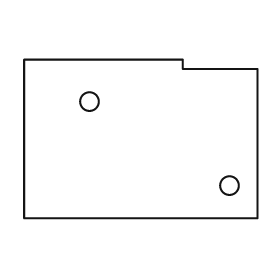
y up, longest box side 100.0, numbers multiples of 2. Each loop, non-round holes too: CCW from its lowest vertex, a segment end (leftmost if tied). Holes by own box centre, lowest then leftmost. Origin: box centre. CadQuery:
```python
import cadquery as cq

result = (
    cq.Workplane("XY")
    .moveTo(-50.0, -34.0)
    .lineTo(50.0, -34.0)
    .lineTo(50.0, 30.0)
    .lineTo(18.0, 30.0)
    .lineTo(18.0, 34.0)
    .lineTo(-50.0, 34.0)
    .close()
    .moveTo(38.0, -20.0)
    .circle(4.0)
    .moveTo(-22.0, 16.0)
    .circle(4.0)
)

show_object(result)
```